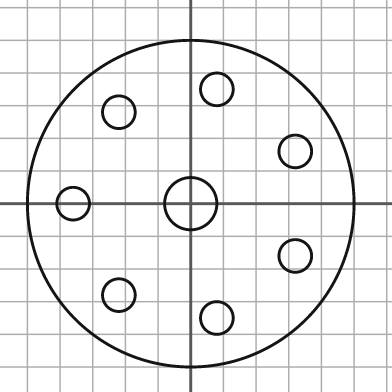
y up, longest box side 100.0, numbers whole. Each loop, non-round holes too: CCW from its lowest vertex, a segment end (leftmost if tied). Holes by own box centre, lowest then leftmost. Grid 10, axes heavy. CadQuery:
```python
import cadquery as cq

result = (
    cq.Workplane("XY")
    .moveTo(0.0, 0.0)
    .circle(50.0)
    .moveTo(8.0, -35.0)
    .circle(5.0)
    .moveTo(-22.0, -28.0)
    .circle(5.0)
    .moveTo(32.0, -16.0)
    .circle(5.0)
    .moveTo(-36.0, 0.0)
    .circle(5.0)
    .moveTo(0.0, 0.0)
    .circle(8.0)
    .moveTo(32.0, 16.0)
    .circle(5.0)
    .moveTo(-22.0, 28.0)
    .circle(5.0)
    .moveTo(8.0, 35.0)
    .circle(5.0)
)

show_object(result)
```